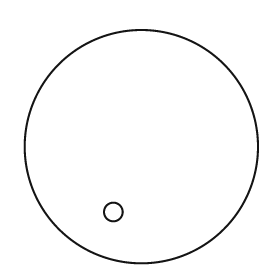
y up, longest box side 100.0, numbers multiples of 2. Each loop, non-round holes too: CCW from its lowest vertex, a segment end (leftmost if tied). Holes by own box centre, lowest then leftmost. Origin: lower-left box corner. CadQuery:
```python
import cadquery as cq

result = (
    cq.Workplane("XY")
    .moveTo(50.0, 50.0)
    .circle(50.0)
    .moveTo(38.0, 22.0)
    .circle(4.0)
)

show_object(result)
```